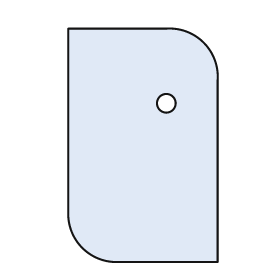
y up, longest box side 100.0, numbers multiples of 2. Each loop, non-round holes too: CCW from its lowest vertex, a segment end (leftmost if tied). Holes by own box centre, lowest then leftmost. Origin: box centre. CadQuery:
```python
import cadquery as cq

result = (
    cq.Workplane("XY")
    .moveTo(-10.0, -50.0)
    .lineTo(32.0, -50.0)
    .lineTo(32.0, 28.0)
    .threePointArc((26.0, 44.0), (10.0, 50.0))
    .lineTo(-32.0, 50.0)
    .lineTo(-32.0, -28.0)
    .threePointArc((-26.0, -44.0), (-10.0, -50.0))
    .close()
    .moveTo(10.0, 18.0)
    .circle(4.0)
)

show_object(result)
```